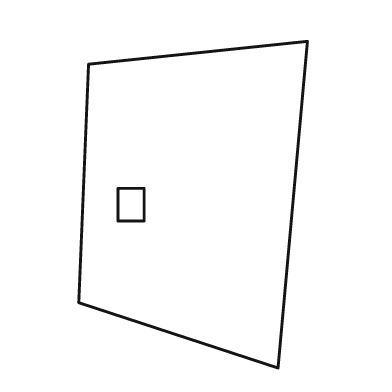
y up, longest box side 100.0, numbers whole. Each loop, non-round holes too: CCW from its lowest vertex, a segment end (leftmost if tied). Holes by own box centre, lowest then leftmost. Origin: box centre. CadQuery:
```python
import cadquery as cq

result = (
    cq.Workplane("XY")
    .moveTo(26.0, -50.0)
    .lineTo(35.0, 50.0)
    .lineTo(-32.0, 43.0)
    .lineTo(-35.0, -30.0)
    .close()
    .moveTo(-23.0, -5.0)
    .lineTo(-15.0, -5.0)
    .lineTo(-15.0, 5.0)
    .lineTo(-23.0, 5.0)
    .close()
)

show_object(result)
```